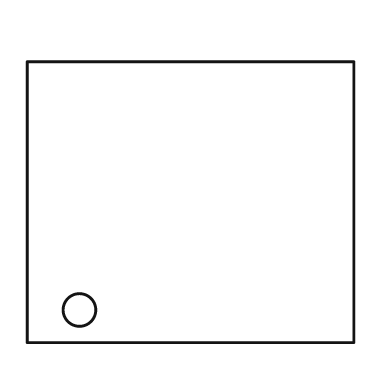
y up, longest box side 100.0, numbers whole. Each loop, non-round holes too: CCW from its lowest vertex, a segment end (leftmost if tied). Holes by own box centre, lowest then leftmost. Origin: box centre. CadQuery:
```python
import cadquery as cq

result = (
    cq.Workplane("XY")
    .moveTo(-50.0, -43.0)
    .lineTo(50.0, -43.0)
    .lineTo(50.0, 43.0)
    .lineTo(-50.0, 43.0)
    .close()
    .moveTo(-34.0, -33.0)
    .circle(5.0)
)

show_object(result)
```